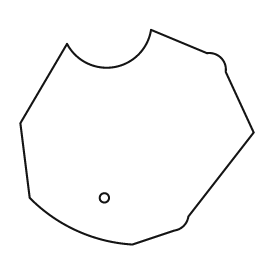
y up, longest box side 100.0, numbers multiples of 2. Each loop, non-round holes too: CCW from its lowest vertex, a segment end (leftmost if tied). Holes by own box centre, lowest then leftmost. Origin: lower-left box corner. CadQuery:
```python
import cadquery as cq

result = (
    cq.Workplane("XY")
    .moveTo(48.0, 0.0)
    .lineTo(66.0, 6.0)
    .threePointArc((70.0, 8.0), (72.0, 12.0))
    .lineTo(100.0, 48.0)
    .lineTo(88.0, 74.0)
    .threePointArc((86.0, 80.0), (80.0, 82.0))
    .lineTo(56.0, 92.0)
    .threePointArc((40.0, 76.0), (20.0, 86.0))
    .lineTo(0.0, 52.0)
    .lineTo(4.0, 20.0)
    .threePointArc((24.0, 6.0), (48.0, 0.0))
    .close()
    .moveTo(36.0, 20.0)
    .circle(2.0)
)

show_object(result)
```